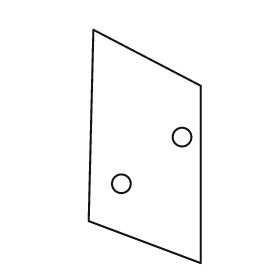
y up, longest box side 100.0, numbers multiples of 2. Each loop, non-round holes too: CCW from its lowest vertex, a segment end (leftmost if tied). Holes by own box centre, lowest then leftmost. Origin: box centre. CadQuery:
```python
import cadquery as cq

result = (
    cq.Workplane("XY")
    .moveTo(24.0, -50.0)
    .lineTo(24.0, 26.0)
    .lineTo(-22.0, 50.0)
    .lineTo(-24.0, -32.0)
    .close()
    .moveTo(-10.0, -16.0)
    .circle(4.0)
    .moveTo(16.0, 4.0)
    .circle(4.0)
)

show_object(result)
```